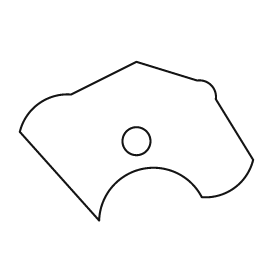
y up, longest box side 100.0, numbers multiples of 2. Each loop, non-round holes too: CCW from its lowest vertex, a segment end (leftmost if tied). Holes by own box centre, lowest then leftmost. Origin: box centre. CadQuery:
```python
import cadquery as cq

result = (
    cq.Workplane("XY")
    .moveTo(-16.0, -34.0)
    .threePointArc((2.0, -12.0), (28.0, -24.0))
    .threePointArc((42.0, -20.0), (50.0, -8.0))
    .lineTo(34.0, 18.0)
    .threePointArc((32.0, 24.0), (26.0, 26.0))
    .lineTo(0.0, 34.0)
    .lineTo(-28.0, 20.0)
    .threePointArc((-42.0, 16.0), (-50.0, 4.0))
    .close()
    .moveTo(0.0, 0.0)
    .circle(6.0)
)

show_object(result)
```